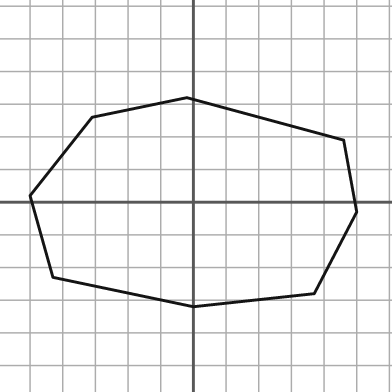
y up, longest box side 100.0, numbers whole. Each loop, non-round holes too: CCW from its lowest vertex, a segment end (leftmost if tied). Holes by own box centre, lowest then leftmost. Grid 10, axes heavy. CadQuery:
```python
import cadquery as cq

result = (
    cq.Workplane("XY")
    .moveTo(0.0, -32.0)
    .lineTo(37.0, -28.0)
    .lineTo(50.0, -3.0)
    .lineTo(46.0, 19.0)
    .lineTo(-2.0, 32.0)
    .lineTo(-31.0, 26.0)
    .lineTo(-50.0, 2.0)
    .lineTo(-43.0, -23.0)
    .close()
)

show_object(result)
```